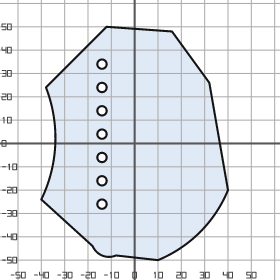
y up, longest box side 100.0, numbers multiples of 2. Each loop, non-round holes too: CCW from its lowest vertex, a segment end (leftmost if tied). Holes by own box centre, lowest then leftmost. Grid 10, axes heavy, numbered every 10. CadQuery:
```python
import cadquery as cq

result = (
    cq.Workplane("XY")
    .moveTo(10.0, -50.0)
    .threePointArc((28.0, -38.0), (40.0, -20.0))
    .lineTo(32.0, 26.0)
    .lineTo(16.0, 48.0)
    .lineTo(-12.0, 50.0)
    .lineTo(-38.0, 24.0)
    .threePointArc((-34.0, 0.0), (-40.0, -24.0))
    .lineTo(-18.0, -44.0)
    .threePointArc((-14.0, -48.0), (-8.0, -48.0))
    .close()
    .moveTo(-14.0, -26.0)
    .circle(2.0)
    .moveTo(-14.0, -16.0)
    .circle(2.0)
    .moveTo(-14.0, -6.0)
    .circle(2.0)
    .moveTo(-14.0, 4.0)
    .circle(2.0)
    .moveTo(-14.0, 14.0)
    .circle(2.0)
    .moveTo(-14.0, 24.0)
    .circle(2.0)
    .moveTo(-14.0, 34.0)
    .circle(2.0)
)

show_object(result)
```